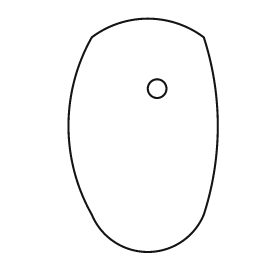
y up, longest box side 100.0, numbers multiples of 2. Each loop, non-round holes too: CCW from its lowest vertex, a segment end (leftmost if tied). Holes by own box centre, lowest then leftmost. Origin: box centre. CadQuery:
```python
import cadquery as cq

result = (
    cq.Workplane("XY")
    .moveTo(-22.0, -34.0)
    .threePointArc((2.0, -50.0), (26.0, -34.0))
    .threePointArc((32.0, 4.0), (26.0, 42.0))
    .threePointArc((2.0, 50.0), (-22.0, 42.0))
    .threePointArc((-32.0, 4.0), (-22.0, -34.0))
    .close()
    .moveTo(6.0, 20.0)
    .circle(4.0)
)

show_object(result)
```